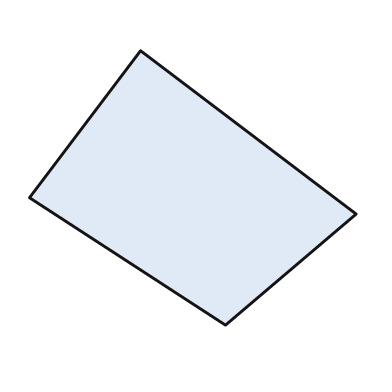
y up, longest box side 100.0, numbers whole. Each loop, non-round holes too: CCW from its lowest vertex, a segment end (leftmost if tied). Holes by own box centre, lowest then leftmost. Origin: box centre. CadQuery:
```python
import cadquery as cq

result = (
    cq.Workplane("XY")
    .moveTo(10.0, -42.0)
    .lineTo(50.0, -8.0)
    .lineTo(-16.0, 42.0)
    .lineTo(-50.0, -3.0)
    .close()
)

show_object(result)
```